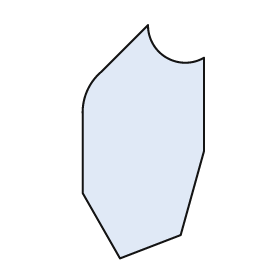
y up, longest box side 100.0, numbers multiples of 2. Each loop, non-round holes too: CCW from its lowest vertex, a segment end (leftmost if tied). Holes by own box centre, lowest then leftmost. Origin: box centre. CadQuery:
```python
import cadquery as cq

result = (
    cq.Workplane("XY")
    .moveTo(-10.0, -50.0)
    .lineTo(16.0, -40.0)
    .lineTo(26.0, -4.0)
    .lineTo(26.0, 36.0)
    .threePointArc((10.0, 36.0), (2.0, 50.0))
    .lineTo(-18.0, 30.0)
    .threePointArc((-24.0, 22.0), (-26.0, 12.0))
    .lineTo(-26.0, -22.0)
    .close()
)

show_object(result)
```